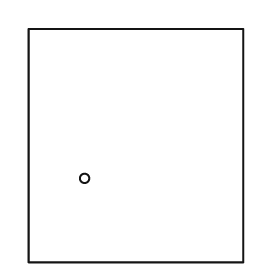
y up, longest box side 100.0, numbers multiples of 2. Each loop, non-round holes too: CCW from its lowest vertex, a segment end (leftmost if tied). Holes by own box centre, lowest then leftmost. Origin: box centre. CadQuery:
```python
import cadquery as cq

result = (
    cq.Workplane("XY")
    .moveTo(-46.0, -50.0)
    .lineTo(46.0, -50.0)
    .lineTo(46.0, 50.0)
    .lineTo(-46.0, 50.0)
    .close()
    .moveTo(-22.0, -14.0)
    .circle(2.0)
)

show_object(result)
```